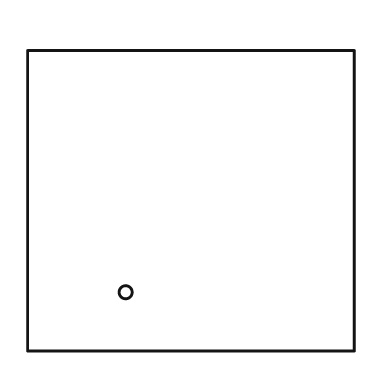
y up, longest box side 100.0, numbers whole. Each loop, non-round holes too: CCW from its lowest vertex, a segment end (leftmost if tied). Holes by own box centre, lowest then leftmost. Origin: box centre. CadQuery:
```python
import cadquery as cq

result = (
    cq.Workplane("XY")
    .moveTo(-50.0, -46.0)
    .lineTo(50.0, -46.0)
    .lineTo(50.0, 46.0)
    .lineTo(-50.0, 46.0)
    .close()
    .moveTo(-20.0, -28.0)
    .circle(2.0)
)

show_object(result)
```